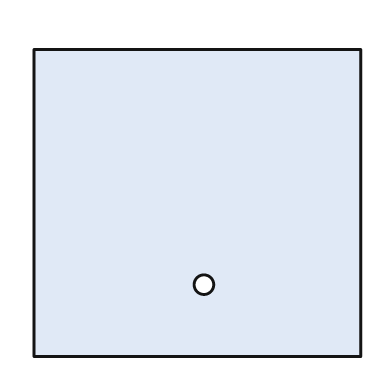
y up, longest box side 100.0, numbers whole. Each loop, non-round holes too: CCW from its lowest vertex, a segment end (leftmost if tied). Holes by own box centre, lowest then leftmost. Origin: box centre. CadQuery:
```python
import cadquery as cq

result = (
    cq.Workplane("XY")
    .moveTo(-50.0, -47.0)
    .lineTo(50.0, -47.0)
    .lineTo(50.0, 47.0)
    .lineTo(-50.0, 47.0)
    .close()
    .moveTo(2.0, -25.0)
    .circle(3.0)
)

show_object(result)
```